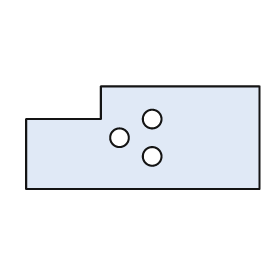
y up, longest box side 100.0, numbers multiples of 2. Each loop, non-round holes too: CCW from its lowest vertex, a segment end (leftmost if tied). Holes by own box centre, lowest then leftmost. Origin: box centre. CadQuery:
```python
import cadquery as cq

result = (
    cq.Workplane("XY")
    .moveTo(-50.0, -22.0)
    .lineTo(50.0, -22.0)
    .lineTo(50.0, 22.0)
    .lineTo(-18.0, 22.0)
    .lineTo(-18.0, 8.0)
    .lineTo(-50.0, 8.0)
    .close()
    .moveTo(4.0, -8.0)
    .circle(4.0)
    .moveTo(-10.0, 0.0)
    .circle(4.0)
    .moveTo(4.0, 8.0)
    .circle(4.0)
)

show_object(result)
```